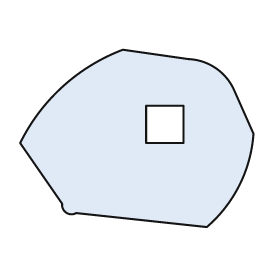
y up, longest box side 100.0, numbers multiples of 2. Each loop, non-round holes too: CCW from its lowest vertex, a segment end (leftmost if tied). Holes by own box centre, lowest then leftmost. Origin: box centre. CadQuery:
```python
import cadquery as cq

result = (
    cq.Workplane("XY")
    .moveTo(30.0, -38.0)
    .threePointArc((44.0, -20.0), (50.0, 2.0))
    .lineTo(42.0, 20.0)
    .threePointArc((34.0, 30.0), (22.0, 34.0))
    .lineTo(-6.0, 38.0)
    .threePointArc((-32.0, 22.0), (-50.0, -2.0))
    .lineTo(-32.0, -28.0)
    .threePointArc((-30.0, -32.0), (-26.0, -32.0))
    .close()
    .moveTo(4.0, -2.0)
    .lineTo(20.0, -2.0)
    .lineTo(20.0, 14.0)
    .lineTo(4.0, 14.0)
    .close()
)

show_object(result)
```